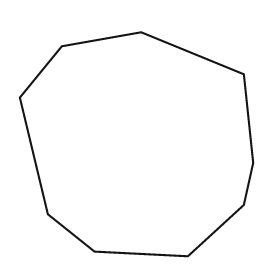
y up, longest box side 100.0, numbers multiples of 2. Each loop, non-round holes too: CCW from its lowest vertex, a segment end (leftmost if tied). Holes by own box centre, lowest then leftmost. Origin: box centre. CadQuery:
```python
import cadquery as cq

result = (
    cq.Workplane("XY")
    .moveTo(22.0, -48.0)
    .lineTo(46.0, -26.0)
    .lineTo(50.0, -8.0)
    .lineTo(46.0, 30.0)
    .lineTo(2.0, 48.0)
    .lineTo(-32.0, 42.0)
    .lineTo(-50.0, 20.0)
    .lineTo(-38.0, -30.0)
    .lineTo(-18.0, -46.0)
    .close()
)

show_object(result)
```